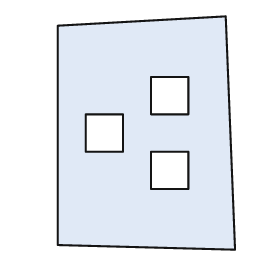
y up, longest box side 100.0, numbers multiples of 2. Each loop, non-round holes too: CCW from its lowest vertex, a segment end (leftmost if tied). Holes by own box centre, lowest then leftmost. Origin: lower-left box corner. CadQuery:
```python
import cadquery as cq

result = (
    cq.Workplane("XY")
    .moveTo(76.0, 0.0)
    .lineTo(72.0, 100.0)
    .lineTo(0.0, 96.0)
    .lineTo(0.0, 2.0)
    .close()
    .moveTo(40.0, 26.0)
    .lineTo(56.0, 26.0)
    .lineTo(56.0, 42.0)
    .lineTo(40.0, 42.0)
    .close()
    .moveTo(12.0, 42.0)
    .lineTo(28.0, 42.0)
    .lineTo(28.0, 58.0)
    .lineTo(12.0, 58.0)
    .close()
    .moveTo(40.0, 58.0)
    .lineTo(56.0, 58.0)
    .lineTo(56.0, 74.0)
    .lineTo(40.0, 74.0)
    .close()
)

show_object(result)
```